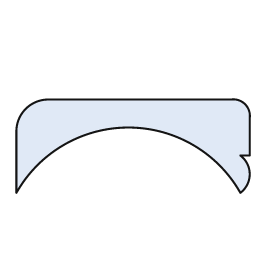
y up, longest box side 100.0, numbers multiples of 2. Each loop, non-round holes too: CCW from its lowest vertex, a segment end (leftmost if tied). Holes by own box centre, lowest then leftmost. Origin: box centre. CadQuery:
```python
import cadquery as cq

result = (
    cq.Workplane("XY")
    .moveTo(-50.0, -20.0)
    .threePointArc((-2.0, 8.0), (46.0, -20.0))
    .threePointArc((50.0, -12.0), (46.0, -4.0))
    .lineTo(50.0, -4.0)
    .lineTo(50.0, 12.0)
    .threePointArc((48.0, 18.0), (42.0, 20.0))
    .lineTo(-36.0, 20.0)
    .threePointArc((-46.0, 16.0), (-50.0, 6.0))
    .close()
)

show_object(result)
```